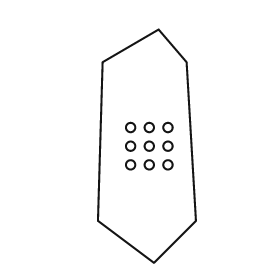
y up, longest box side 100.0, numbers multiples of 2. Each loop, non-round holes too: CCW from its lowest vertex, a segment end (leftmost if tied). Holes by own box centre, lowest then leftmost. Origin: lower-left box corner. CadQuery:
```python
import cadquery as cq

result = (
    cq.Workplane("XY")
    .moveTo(24.0, 0.0)
    .lineTo(42.0, 18.0)
    .lineTo(38.0, 86.0)
    .lineTo(26.0, 100.0)
    .lineTo(2.0, 86.0)
    .lineTo(0.0, 18.0)
    .close()
    .moveTo(14.0, 42.0)
    .circle(2.0)
    .moveTo(22.0, 42.0)
    .circle(2.0)
    .moveTo(30.0, 42.0)
    .circle(2.0)
    .moveTo(14.0, 50.0)
    .circle(2.0)
    .moveTo(22.0, 50.0)
    .circle(2.0)
    .moveTo(30.0, 50.0)
    .circle(2.0)
    .moveTo(14.0, 58.0)
    .circle(2.0)
    .moveTo(22.0, 58.0)
    .circle(2.0)
    .moveTo(30.0, 58.0)
    .circle(2.0)
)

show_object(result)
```